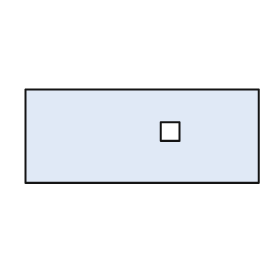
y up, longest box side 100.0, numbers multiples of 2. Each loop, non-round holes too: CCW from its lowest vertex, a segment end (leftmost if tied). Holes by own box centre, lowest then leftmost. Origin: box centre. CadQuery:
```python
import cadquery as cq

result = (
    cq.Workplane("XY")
    .moveTo(-50.0, -20.0)
    .lineTo(50.0, -20.0)
    .lineTo(50.0, 20.0)
    .lineTo(-50.0, 20.0)
    .close()
    .moveTo(8.0, -2.0)
    .lineTo(16.0, -2.0)
    .lineTo(16.0, 6.0)
    .lineTo(8.0, 6.0)
    .close()
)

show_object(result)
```